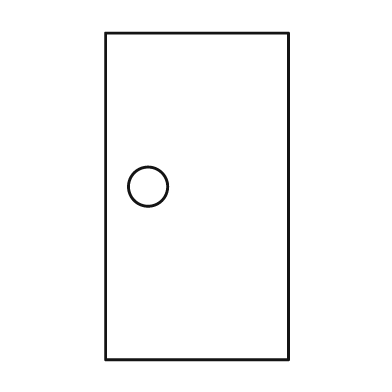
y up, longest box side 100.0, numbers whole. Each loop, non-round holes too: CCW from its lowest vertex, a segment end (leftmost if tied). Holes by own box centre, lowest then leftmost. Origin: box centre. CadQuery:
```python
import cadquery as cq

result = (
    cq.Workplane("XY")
    .moveTo(-28.0, -50.0)
    .lineTo(28.0, -50.0)
    .lineTo(28.0, 50.0)
    .lineTo(-28.0, 50.0)
    .close()
    .moveTo(-15.0, 3.0)
    .circle(6.0)
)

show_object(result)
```